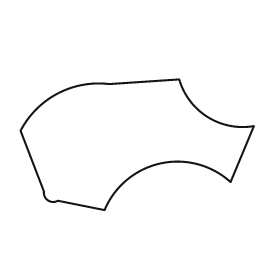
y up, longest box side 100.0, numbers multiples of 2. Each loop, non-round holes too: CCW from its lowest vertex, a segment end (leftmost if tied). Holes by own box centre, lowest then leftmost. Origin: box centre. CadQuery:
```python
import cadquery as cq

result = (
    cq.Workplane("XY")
    .moveTo(-14.0, -28.0)
    .threePointArc((10.0, -8.0), (40.0, -16.0))
    .lineTo(50.0, 8.0)
    .threePointArc((30.0, 12.0), (18.0, 28.0))
    .lineTo(-12.0, 26.0)
    .threePointArc((-34.0, 22.0), (-50.0, 6.0))
    .lineTo(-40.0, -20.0)
    .threePointArc((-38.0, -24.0), (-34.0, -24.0))
    .close()
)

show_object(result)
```